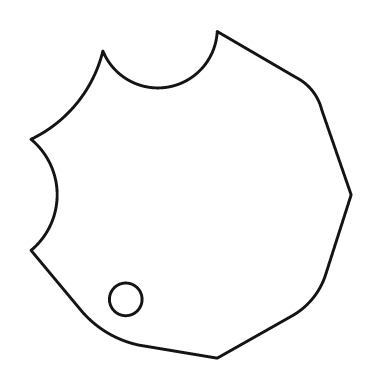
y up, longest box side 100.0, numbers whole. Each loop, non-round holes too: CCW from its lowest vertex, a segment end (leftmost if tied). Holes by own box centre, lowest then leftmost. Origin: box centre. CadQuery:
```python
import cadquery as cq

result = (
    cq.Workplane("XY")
    .moveTo(8.0, -50.0)
    .lineTo(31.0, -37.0)
    .threePointArc((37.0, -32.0), (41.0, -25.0))
    .lineTo(49.0, 0.0)
    .lineTo(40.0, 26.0)
    .threePointArc((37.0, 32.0), (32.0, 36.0))
    .lineTo(8.0, 50.0)
    .threePointArc((-7.0, 33.0), (-27.0, 44.0))
    .threePointArc((-35.0, 28.0), (-49.0, 17.0))
    .threePointArc((-41.0, 0.0), (-49.0, -17.0))
    .lineTo(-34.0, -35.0)
    .threePointArc((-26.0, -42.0), (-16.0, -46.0))
    .close()
    .moveTo(-20.0, -32.0)
    .circle(5.0)
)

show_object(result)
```